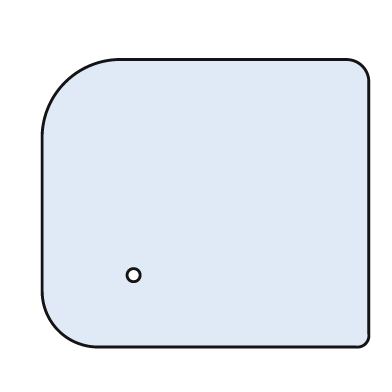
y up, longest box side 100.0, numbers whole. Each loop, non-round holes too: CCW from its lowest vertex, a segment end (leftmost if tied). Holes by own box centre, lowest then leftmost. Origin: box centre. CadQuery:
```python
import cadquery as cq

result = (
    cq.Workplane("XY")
    .moveTo(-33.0, -44.0)
    .lineTo(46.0, -44.0)
    .threePointArc((49.0, -43.0), (50.0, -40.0))
    .lineTo(50.0, 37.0)
    .threePointArc((48.0, 42.0), (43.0, 44.0))
    .lineTo(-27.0, 44.0)
    .threePointArc((-43.0, 37.0), (-50.0, 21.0))
    .lineTo(-50.0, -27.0)
    .threePointArc((-45.0, -39.0), (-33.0, -44.0))
    .close()
    .moveTo(-22.0, -22.0)
    .circle(2.0)
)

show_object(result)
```